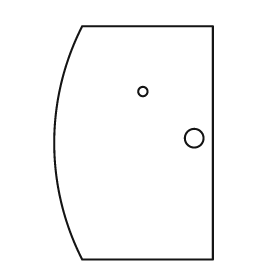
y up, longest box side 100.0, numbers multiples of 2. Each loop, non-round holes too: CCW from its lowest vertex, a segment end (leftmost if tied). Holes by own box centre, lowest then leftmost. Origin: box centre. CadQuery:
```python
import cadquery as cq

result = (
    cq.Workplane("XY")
    .moveTo(-22.0, -50.0)
    .lineTo(34.0, -50.0)
    .lineTo(34.0, 50.0)
    .lineTo(-22.0, 50.0)
    .threePointArc((-34.0, 0.0), (-22.0, -50.0))
    .close()
    .moveTo(26.0, 2.0)
    .circle(4.0)
    .moveTo(4.0, 22.0)
    .circle(2.0)
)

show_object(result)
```